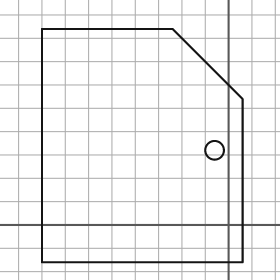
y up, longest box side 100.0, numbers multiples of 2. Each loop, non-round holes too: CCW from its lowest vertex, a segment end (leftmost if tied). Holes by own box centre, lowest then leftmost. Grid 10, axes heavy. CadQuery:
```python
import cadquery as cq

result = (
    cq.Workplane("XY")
    .moveTo(-80.0, -16.0)
    .lineTo(6.0, -16.0)
    .lineTo(6.0, 54.0)
    .lineTo(-24.0, 84.0)
    .lineTo(-80.0, 84.0)
    .close()
    .moveTo(-6.0, 32.0)
    .circle(4.0)
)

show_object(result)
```